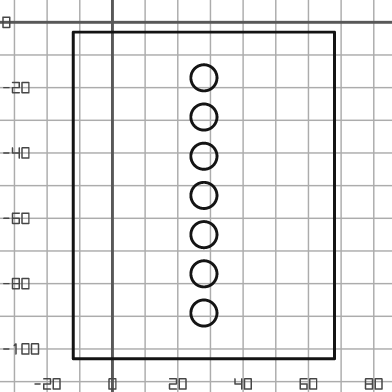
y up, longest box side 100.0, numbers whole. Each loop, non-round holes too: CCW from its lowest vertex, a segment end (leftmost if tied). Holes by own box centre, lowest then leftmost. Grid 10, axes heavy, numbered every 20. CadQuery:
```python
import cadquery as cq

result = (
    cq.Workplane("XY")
    .moveTo(-12.0, -103.0)
    .lineTo(68.0, -103.0)
    .lineTo(68.0, -3.0)
    .lineTo(-12.0, -3.0)
    .close()
    .moveTo(28.0, -89.0)
    .circle(4.0)
    .moveTo(28.0, -77.0)
    .circle(4.0)
    .moveTo(28.0, -65.0)
    .circle(4.0)
    .moveTo(28.0, -53.0)
    .circle(4.0)
    .moveTo(28.0, -41.0)
    .circle(4.0)
    .moveTo(28.0, -29.0)
    .circle(4.0)
    .moveTo(28.0, -17.0)
    .circle(4.0)
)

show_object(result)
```